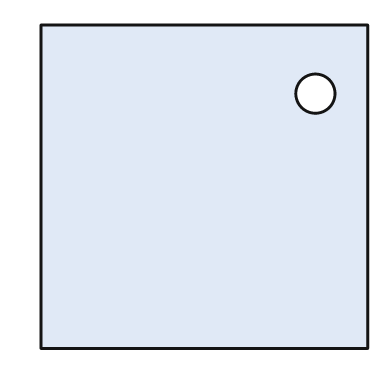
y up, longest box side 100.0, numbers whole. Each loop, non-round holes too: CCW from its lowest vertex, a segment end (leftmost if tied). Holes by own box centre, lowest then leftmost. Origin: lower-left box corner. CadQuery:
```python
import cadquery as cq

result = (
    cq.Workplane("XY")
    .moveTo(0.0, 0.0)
    .lineTo(100.0, 0.0)
    .lineTo(100.0, 99.0)
    .lineTo(0.0, 99.0)
    .close()
    .moveTo(84.0, 78.0)
    .circle(6.0)
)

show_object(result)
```